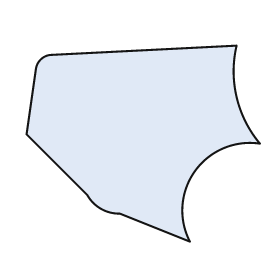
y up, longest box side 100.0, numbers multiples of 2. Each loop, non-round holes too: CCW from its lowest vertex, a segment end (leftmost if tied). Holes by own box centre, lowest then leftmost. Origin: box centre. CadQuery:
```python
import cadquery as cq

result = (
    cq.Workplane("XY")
    .moveTo(20.0, -42.0)
    .threePointArc((22.0, -12.0), (50.0, 0.0))
    .threePointArc((40.0, 20.0), (40.0, 42.0))
    .lineTo(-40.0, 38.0)
    .threePointArc((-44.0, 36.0), (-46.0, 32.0))
    .lineTo(-50.0, 4.0)
    .lineTo(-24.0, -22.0)
    .threePointArc((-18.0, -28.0), (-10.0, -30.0))
    .close()
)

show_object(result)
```